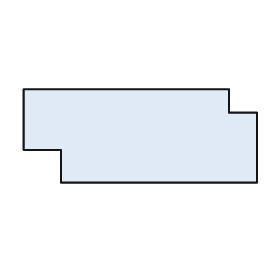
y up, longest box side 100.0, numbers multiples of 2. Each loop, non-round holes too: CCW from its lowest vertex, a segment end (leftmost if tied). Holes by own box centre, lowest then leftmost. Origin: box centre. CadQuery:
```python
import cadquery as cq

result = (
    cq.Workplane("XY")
    .moveTo(-34.0, -20.0)
    .lineTo(50.0, -20.0)
    .lineTo(50.0, 10.0)
    .lineTo(38.0, 10.0)
    .lineTo(38.0, 20.0)
    .lineTo(-50.0, 20.0)
    .lineTo(-50.0, -6.0)
    .lineTo(-34.0, -6.0)
    .close()
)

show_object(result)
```